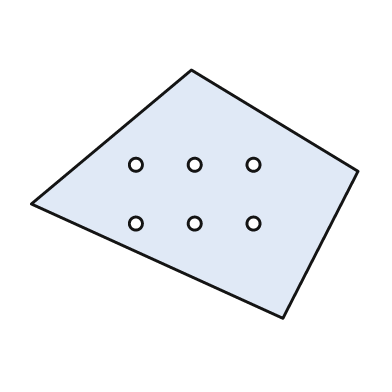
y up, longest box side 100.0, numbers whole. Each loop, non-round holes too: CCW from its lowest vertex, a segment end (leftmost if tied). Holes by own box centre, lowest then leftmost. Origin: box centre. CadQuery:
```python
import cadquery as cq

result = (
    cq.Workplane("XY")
    .moveTo(27.0, -38.0)
    .lineTo(50.0, 7.0)
    .lineTo(-1.0, 38.0)
    .lineTo(-50.0, -3.0)
    .close()
    .moveTo(-18.0, -9.0)
    .circle(2.0)
    .moveTo(0.0, -9.0)
    .circle(2.0)
    .moveTo(18.0, -9.0)
    .circle(2.0)
    .moveTo(-18.0, 9.0)
    .circle(2.0)
    .moveTo(0.0, 9.0)
    .circle(2.0)
    .moveTo(18.0, 9.0)
    .circle(2.0)
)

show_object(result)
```